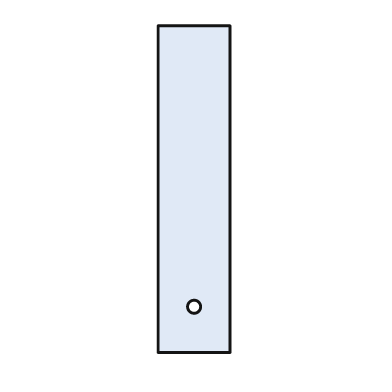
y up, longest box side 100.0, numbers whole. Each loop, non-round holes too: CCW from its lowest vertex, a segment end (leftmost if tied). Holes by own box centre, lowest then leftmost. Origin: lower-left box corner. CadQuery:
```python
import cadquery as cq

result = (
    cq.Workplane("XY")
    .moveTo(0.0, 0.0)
    .lineTo(22.0, 0.0)
    .lineTo(22.0, 100.0)
    .lineTo(0.0, 100.0)
    .close()
    .moveTo(11.0, 14.0)
    .circle(2.0)
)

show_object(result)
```